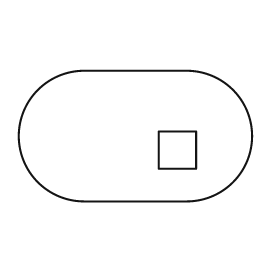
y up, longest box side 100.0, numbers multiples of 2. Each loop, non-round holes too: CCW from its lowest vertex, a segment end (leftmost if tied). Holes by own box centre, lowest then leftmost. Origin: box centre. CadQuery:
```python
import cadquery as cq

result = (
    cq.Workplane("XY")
    .moveTo(-22.0, -28.0)
    .lineTo(22.0, -28.0)
    .threePointArc((50.0, 0.0), (22.0, 28.0))
    .lineTo(-22.0, 28.0)
    .threePointArc((-50.0, 0.0), (-22.0, -28.0))
    .close()
    .moveTo(10.0, -14.0)
    .lineTo(26.0, -14.0)
    .lineTo(26.0, 2.0)
    .lineTo(10.0, 2.0)
    .close()
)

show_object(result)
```